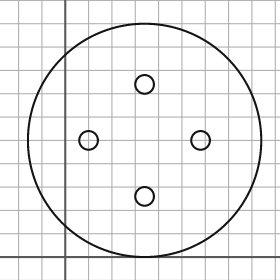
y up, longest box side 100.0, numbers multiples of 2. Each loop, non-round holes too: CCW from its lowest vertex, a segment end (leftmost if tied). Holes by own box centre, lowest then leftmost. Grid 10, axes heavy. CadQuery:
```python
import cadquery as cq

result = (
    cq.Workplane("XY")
    .moveTo(34.0, 50.0)
    .circle(50.0)
    .moveTo(34.0, 26.0)
    .circle(4.0)
    .moveTo(10.0, 50.0)
    .circle(4.0)
    .moveTo(58.0, 50.0)
    .circle(4.0)
    .moveTo(34.0, 74.0)
    .circle(4.0)
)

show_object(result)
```